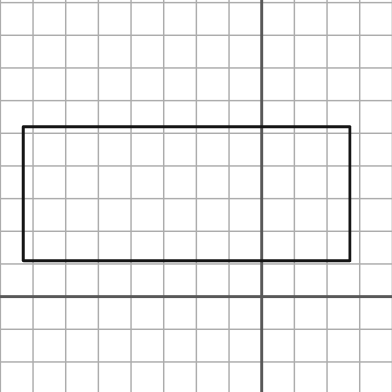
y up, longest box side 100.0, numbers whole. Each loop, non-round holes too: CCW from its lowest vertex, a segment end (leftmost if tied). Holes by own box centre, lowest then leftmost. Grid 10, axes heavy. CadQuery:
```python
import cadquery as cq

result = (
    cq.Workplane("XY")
    .moveTo(-73.0, 11.0)
    .lineTo(27.0, 11.0)
    .lineTo(27.0, 52.0)
    .lineTo(-73.0, 52.0)
    .close()
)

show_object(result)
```